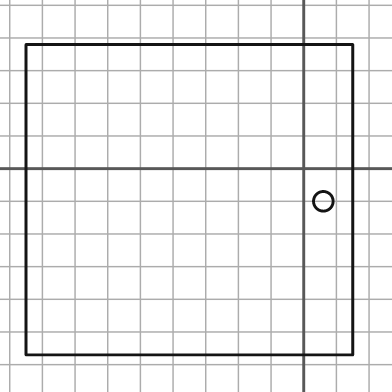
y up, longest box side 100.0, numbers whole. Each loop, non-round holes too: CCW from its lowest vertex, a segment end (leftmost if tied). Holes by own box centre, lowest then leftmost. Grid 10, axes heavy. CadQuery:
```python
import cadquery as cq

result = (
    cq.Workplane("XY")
    .moveTo(-85.0, -57.0)
    .lineTo(15.0, -57.0)
    .lineTo(15.0, 38.0)
    .lineTo(-85.0, 38.0)
    .close()
    .moveTo(6.0, -10.0)
    .circle(3.0)
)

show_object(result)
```